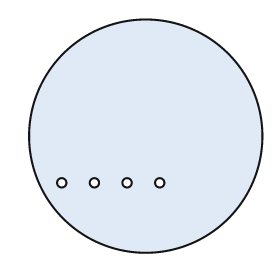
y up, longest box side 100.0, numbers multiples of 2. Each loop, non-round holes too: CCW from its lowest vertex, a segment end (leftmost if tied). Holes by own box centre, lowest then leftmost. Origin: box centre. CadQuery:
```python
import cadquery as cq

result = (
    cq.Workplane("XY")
    .moveTo(0.0, 0.0)
    .circle(50.0)
    .moveTo(-36.0, -20.0)
    .circle(2.0)
    .moveTo(-22.0, -20.0)
    .circle(2.0)
    .moveTo(-8.0, -20.0)
    .circle(2.0)
    .moveTo(6.0, -20.0)
    .circle(2.0)
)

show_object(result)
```